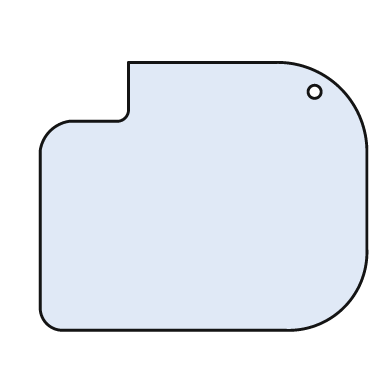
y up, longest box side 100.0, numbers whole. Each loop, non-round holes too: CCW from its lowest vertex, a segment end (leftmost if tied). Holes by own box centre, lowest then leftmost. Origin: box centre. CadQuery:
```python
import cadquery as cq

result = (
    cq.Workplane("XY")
    .moveTo(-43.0, -41.0)
    .lineTo(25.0, -41.0)
    .threePointArc((43.0, -34.0), (50.0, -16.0))
    .lineTo(50.0, 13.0)
    .threePointArc((42.0, 33.0), (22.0, 41.0))
    .lineTo(-23.0, 41.0)
    .lineTo(-23.0, 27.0)
    .threePointArc((-24.0, 24.0), (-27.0, 23.0))
    .lineTo(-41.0, 23.0)
    .threePointArc((-47.0, 20.0), (-50.0, 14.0))
    .lineTo(-50.0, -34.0)
    .threePointArc((-48.0, -39.0), (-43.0, -41.0))
    .close()
    .moveTo(34.0, 32.0)
    .circle(2.0)
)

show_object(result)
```